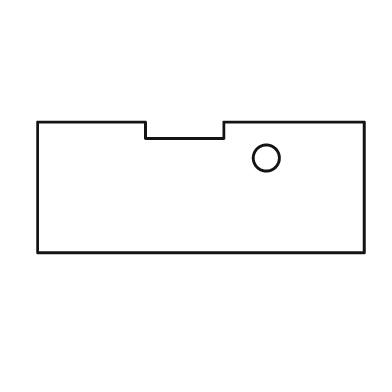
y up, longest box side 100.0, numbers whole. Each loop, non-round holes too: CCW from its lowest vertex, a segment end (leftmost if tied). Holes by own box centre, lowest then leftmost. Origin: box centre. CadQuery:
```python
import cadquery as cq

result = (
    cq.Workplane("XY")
    .moveTo(-50.0, -20.0)
    .lineTo(50.0, -20.0)
    .lineTo(50.0, 20.0)
    .lineTo(7.0, 20.0)
    .lineTo(7.0, 15.0)
    .lineTo(-17.0, 15.0)
    .lineTo(-17.0, 20.0)
    .lineTo(-50.0, 20.0)
    .close()
    .moveTo(20.0, 9.0)
    .circle(4.0)
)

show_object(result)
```